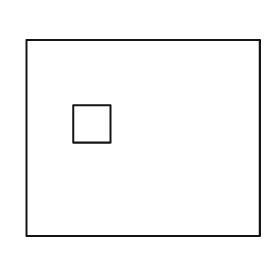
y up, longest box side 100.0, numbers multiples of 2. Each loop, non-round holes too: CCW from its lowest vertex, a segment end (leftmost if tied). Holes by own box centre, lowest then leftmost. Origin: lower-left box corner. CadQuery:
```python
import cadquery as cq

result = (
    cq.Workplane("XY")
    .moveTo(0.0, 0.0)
    .lineTo(100.0, 0.0)
    .lineTo(100.0, 84.0)
    .lineTo(0.0, 84.0)
    .close()
    .moveTo(20.0, 40.0)
    .lineTo(36.0, 40.0)
    .lineTo(36.0, 56.0)
    .lineTo(20.0, 56.0)
    .close()
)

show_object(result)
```